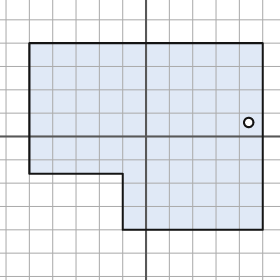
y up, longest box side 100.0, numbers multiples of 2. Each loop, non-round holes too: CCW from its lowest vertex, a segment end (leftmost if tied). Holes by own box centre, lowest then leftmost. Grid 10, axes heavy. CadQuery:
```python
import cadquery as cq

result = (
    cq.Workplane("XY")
    .moveTo(-10.0, -40.0)
    .lineTo(50.0, -40.0)
    .lineTo(50.0, 40.0)
    .lineTo(-50.0, 40.0)
    .lineTo(-50.0, -16.0)
    .lineTo(-10.0, -16.0)
    .close()
    .moveTo(44.0, 6.0)
    .circle(2.0)
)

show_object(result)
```